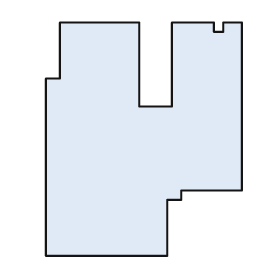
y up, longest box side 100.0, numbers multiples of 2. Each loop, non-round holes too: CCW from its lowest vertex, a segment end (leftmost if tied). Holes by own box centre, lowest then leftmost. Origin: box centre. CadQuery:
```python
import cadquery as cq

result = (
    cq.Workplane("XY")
    .moveTo(-42.0, -50.0)
    .lineTo(10.0, -50.0)
    .lineTo(10.0, -26.0)
    .lineTo(16.0, -26.0)
    .lineTo(16.0, -22.0)
    .lineTo(42.0, -22.0)
    .lineTo(42.0, 50.0)
    .lineTo(34.0, 50.0)
    .lineTo(34.0, 46.0)
    .lineTo(30.0, 46.0)
    .lineTo(30.0, 50.0)
    .lineTo(12.0, 50.0)
    .lineTo(12.0, 14.0)
    .lineTo(-2.0, 14.0)
    .lineTo(-2.0, 50.0)
    .lineTo(-36.0, 50.0)
    .lineTo(-36.0, 26.0)
    .lineTo(-42.0, 26.0)
    .close()
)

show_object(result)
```